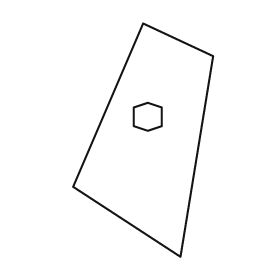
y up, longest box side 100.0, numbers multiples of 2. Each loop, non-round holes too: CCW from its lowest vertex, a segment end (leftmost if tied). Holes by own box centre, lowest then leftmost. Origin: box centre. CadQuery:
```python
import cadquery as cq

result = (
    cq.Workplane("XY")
    .moveTo(16.0, -50.0)
    .lineTo(30.0, 36.0)
    .lineTo(0.0, 50.0)
    .lineTo(-30.0, -20.0)
    .close()
    .moveTo(2.0, 4.0)
    .lineTo(8.0, 6.0)
    .lineTo(8.0, 14.0)
    .lineTo(2.0, 16.0)
    .lineTo(-4.0, 14.0)
    .lineTo(-4.0, 6.0)
    .close()
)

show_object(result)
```